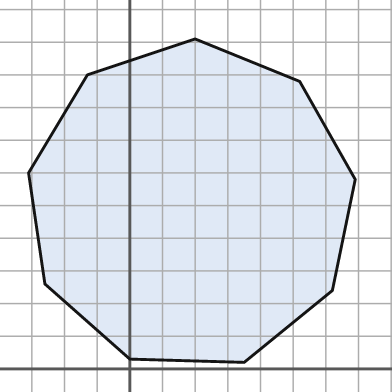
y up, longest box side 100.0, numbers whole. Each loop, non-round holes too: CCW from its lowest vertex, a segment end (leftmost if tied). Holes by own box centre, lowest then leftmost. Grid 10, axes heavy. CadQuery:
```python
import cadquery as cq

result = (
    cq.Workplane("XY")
    .moveTo(35.0, 2.0)
    .lineTo(62.0, 24.0)
    .lineTo(69.0, 58.0)
    .lineTo(52.0, 88.0)
    .lineTo(20.0, 101.0)
    .lineTo(-13.0, 90.0)
    .lineTo(-31.0, 60.0)
    .lineTo(-26.0, 26.0)
    .lineTo(0.0, 3.0)
    .close()
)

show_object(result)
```